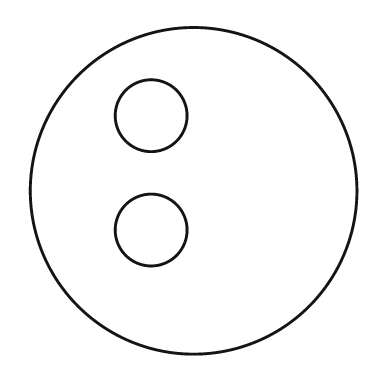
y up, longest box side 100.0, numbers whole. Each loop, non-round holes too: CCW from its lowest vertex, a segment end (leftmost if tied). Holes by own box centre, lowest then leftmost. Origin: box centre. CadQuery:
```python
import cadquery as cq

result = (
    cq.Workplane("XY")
    .moveTo(0.0, 0.0)
    .circle(50.0)
    .moveTo(-13.0, -12.0)
    .circle(11.0)
    .moveTo(-13.0, 23.0)
    .circle(11.0)
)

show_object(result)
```